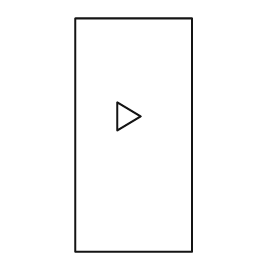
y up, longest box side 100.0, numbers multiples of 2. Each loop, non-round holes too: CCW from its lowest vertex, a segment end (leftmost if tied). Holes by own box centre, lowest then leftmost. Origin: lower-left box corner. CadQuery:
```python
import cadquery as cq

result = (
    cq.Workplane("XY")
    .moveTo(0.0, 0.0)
    .lineTo(50.0, 0.0)
    .lineTo(50.0, 100.0)
    .lineTo(0.0, 100.0)
    .close()
    .moveTo(18.0, 52.0)
    .lineTo(28.0, 58.0)
    .lineTo(18.0, 64.0)
    .close()
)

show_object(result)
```